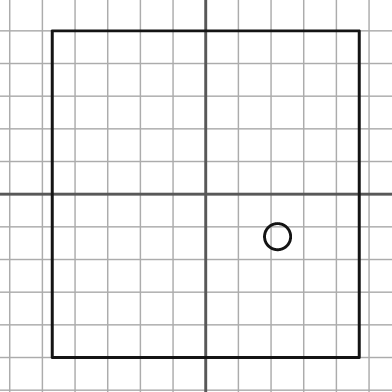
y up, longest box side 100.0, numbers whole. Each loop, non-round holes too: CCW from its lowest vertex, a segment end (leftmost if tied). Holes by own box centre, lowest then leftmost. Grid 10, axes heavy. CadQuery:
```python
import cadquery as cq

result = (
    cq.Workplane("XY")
    .moveTo(-47.0, -50.0)
    .lineTo(47.0, -50.0)
    .lineTo(47.0, 50.0)
    .lineTo(-47.0, 50.0)
    .close()
    .moveTo(22.0, -13.0)
    .circle(4.0)
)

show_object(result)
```